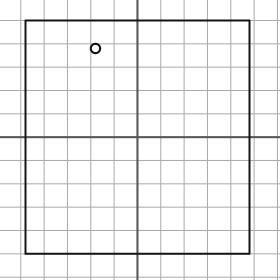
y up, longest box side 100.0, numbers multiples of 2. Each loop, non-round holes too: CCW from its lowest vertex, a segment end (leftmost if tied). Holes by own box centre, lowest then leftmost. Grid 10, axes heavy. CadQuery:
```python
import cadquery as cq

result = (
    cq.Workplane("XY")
    .moveTo(-48.0, -50.0)
    .lineTo(48.0, -50.0)
    .lineTo(48.0, 50.0)
    .lineTo(-48.0, 50.0)
    .close()
    .moveTo(-18.0, 38.0)
    .circle(2.0)
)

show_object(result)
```